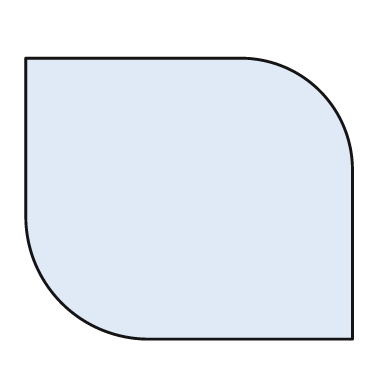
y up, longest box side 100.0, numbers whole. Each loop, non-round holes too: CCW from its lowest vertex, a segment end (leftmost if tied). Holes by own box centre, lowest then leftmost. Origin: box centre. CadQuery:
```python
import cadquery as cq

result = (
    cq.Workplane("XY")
    .moveTo(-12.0, -43.0)
    .lineTo(50.0, -43.0)
    .lineTo(50.0, 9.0)
    .threePointArc((40.0, 33.0), (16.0, 43.0))
    .lineTo(-50.0, 43.0)
    .lineTo(-50.0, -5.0)
    .threePointArc((-39.0, -32.0), (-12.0, -43.0))
    .close()
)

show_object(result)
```